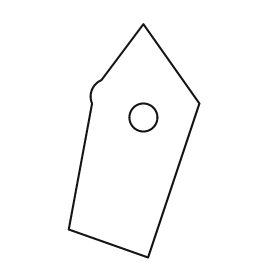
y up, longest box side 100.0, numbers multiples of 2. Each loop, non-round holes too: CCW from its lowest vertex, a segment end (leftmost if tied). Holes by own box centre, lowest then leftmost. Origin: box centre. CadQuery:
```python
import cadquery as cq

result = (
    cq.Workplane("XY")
    .moveTo(6.0, -50.0)
    .lineTo(28.0, 16.0)
    .lineTo(4.0, 50.0)
    .lineTo(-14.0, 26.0)
    .threePointArc((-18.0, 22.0), (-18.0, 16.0))
    .lineTo(-28.0, -38.0)
    .close()
    .moveTo(4.0, 10.0)
    .circle(6.0)
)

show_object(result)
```